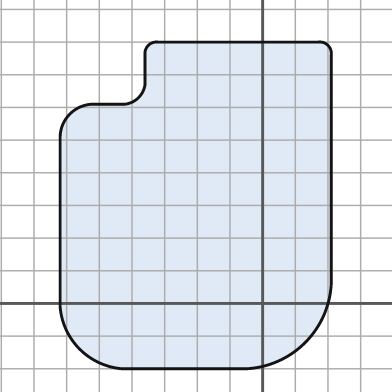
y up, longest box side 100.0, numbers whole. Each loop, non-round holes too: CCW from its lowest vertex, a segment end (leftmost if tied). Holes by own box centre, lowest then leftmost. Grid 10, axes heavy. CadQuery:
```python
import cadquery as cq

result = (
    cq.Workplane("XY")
    .moveTo(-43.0, -20.0)
    .lineTo(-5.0, -20.0)
    .threePointArc((13.0, -12.0), (21.0, 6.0))
    .lineTo(21.0, 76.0)
    .threePointArc((20.0, 79.0), (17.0, 80.0))
    .lineTo(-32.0, 80.0)
    .threePointArc((-35.0, 79.0), (-36.0, 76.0))
    .lineTo(-36.0, 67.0)
    .threePointArc((-38.0, 63.0), (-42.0, 61.0))
    .lineTo(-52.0, 61.0)
    .threePointArc((-59.0, 58.0), (-62.0, 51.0))
    .lineTo(-62.0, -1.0)
    .threePointArc((-56.0, -14.0), (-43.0, -20.0))
    .close()
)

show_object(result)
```